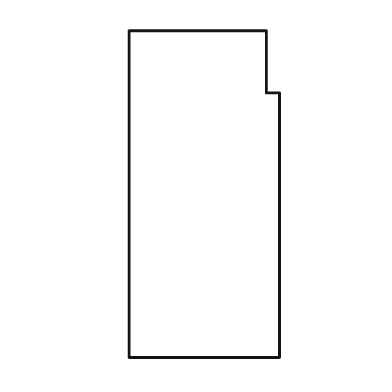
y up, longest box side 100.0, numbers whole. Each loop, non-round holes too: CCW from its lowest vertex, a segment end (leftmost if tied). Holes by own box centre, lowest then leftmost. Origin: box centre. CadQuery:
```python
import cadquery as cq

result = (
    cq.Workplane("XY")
    .moveTo(-23.0, -50.0)
    .lineTo(23.0, -50.0)
    .lineTo(23.0, 31.0)
    .lineTo(19.0, 31.0)
    .lineTo(19.0, 50.0)
    .lineTo(-23.0, 50.0)
    .close()
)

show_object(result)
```